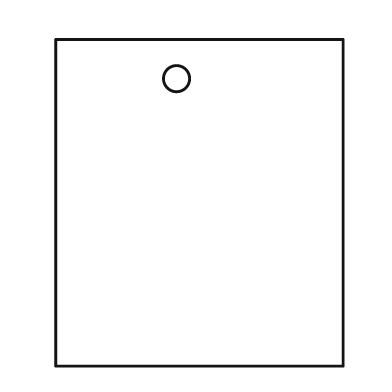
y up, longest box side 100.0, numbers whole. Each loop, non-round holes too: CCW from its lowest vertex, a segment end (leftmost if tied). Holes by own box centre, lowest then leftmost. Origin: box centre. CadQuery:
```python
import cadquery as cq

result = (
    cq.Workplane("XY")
    .moveTo(-44.0, -50.0)
    .lineTo(44.0, -50.0)
    .lineTo(44.0, 50.0)
    .lineTo(-44.0, 50.0)
    .close()
    .moveTo(-7.0, 38.0)
    .circle(4.0)
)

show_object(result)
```